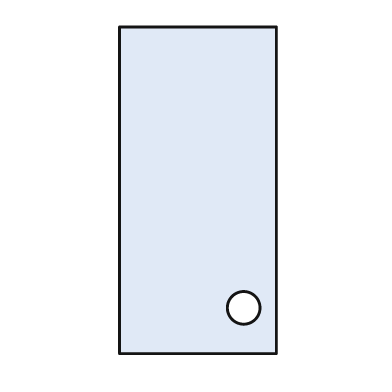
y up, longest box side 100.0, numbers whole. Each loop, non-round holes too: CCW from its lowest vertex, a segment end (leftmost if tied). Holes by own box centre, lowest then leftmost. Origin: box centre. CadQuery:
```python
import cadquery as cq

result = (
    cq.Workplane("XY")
    .moveTo(-24.0, -50.0)
    .lineTo(24.0, -50.0)
    .lineTo(24.0, 50.0)
    .lineTo(-24.0, 50.0)
    .close()
    .moveTo(14.0, -36.0)
    .circle(5.0)
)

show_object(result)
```